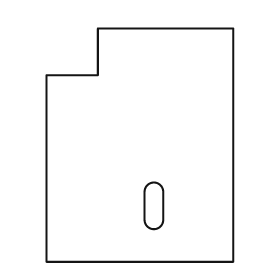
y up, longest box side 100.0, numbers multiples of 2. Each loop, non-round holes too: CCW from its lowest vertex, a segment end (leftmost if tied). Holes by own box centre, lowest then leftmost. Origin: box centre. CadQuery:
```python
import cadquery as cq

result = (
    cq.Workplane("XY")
    .moveTo(-40.0, -50.0)
    .lineTo(40.0, -50.0)
    .lineTo(40.0, 50.0)
    .lineTo(-18.0, 50.0)
    .lineTo(-18.0, 30.0)
    .lineTo(-40.0, 30.0)
    .close()
    .moveTo(2.0, -32.0)
    .threePointArc((6.0, -36.0), (10.0, -32.0))
    .lineTo(10.0, -20.0)
    .threePointArc((6.0, -16.0), (2.0, -20.0))
    .close()
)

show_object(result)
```